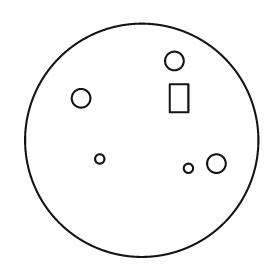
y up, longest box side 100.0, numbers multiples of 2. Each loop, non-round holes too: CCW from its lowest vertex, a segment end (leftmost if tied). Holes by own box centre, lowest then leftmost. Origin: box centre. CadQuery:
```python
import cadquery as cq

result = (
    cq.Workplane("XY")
    .moveTo(0.0, 0.0)
    .circle(50.0)
    .moveTo(20.0, -12.0)
    .circle(2.0)
    .moveTo(32.0, -10.0)
    .circle(4.0)
    .moveTo(-18.0, -8.0)
    .circle(2.0)
    .moveTo(-26.0, 18.0)
    .circle(4.0)
    .moveTo(12.0, 12.0)
    .lineTo(20.0, 12.0)
    .lineTo(20.0, 24.0)
    .lineTo(12.0, 24.0)
    .close()
    .moveTo(14.0, 34.0)
    .circle(4.0)
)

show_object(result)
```